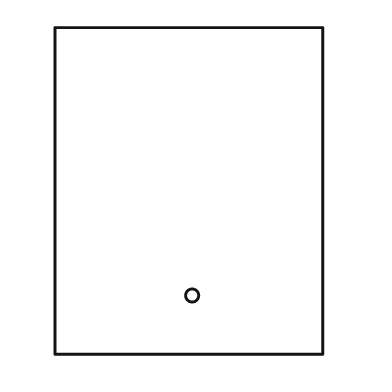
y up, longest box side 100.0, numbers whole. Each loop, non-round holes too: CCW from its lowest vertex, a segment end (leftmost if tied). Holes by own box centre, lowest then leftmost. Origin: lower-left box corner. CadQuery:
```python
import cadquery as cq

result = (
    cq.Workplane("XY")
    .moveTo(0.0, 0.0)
    .lineTo(82.0, 0.0)
    .lineTo(82.0, 100.0)
    .lineTo(0.0, 100.0)
    .close()
    .moveTo(42.0, 18.0)
    .circle(2.0)
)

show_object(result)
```